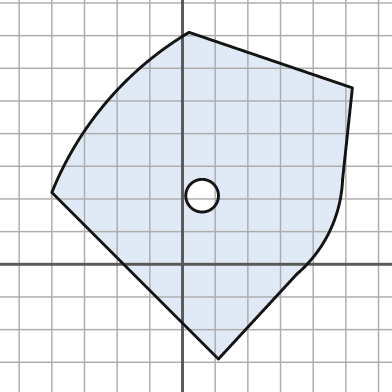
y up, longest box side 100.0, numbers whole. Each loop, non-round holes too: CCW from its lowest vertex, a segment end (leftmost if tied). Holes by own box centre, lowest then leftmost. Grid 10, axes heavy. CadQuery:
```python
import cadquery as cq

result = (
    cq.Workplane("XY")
    .moveTo(11.0, -29.0)
    .lineTo(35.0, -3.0)
    .threePointArc((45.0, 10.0), (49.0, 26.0))
    .lineTo(52.0, 54.0)
    .lineTo(2.0, 71.0)
    .threePointArc((-23.0, 50.0), (-40.0, 22.0))
    .close()
    .moveTo(6.0, 21.0)
    .circle(5.0)
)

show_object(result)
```